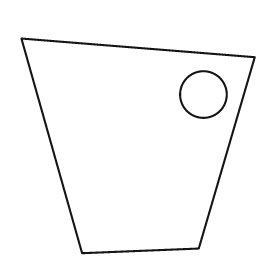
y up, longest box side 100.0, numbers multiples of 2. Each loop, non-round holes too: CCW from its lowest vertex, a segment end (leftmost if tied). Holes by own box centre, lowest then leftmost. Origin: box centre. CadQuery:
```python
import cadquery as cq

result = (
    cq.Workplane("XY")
    .moveTo(-24.0, -46.0)
    .lineTo(26.0, -44.0)
    .lineTo(50.0, 38.0)
    .lineTo(-50.0, 46.0)
    .close()
    .moveTo(28.0, 22.0)
    .circle(10.0)
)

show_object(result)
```